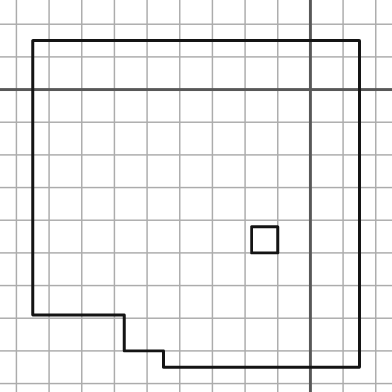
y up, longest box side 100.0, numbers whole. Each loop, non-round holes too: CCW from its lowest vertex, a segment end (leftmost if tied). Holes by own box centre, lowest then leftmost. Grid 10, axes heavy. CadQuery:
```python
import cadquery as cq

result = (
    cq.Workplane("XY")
    .moveTo(-45.0, -85.0)
    .lineTo(15.0, -85.0)
    .lineTo(15.0, 15.0)
    .lineTo(-85.0, 15.0)
    .lineTo(-85.0, -69.0)
    .lineTo(-57.0, -69.0)
    .lineTo(-57.0, -80.0)
    .lineTo(-45.0, -80.0)
    .close()
    .moveTo(-18.0, -50.0)
    .lineTo(-10.0, -50.0)
    .lineTo(-10.0, -42.0)
    .lineTo(-18.0, -42.0)
    .close()
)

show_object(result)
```